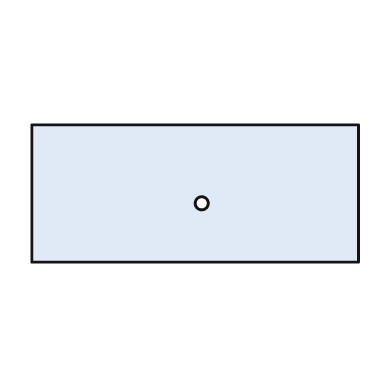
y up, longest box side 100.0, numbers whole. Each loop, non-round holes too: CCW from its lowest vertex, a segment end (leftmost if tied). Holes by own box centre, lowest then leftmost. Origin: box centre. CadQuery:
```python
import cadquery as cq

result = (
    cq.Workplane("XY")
    .moveTo(-50.0, -21.0)
    .lineTo(50.0, -21.0)
    .lineTo(50.0, 21.0)
    .lineTo(-50.0, 21.0)
    .close()
    .moveTo(2.0, -3.0)
    .circle(2.0)
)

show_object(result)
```